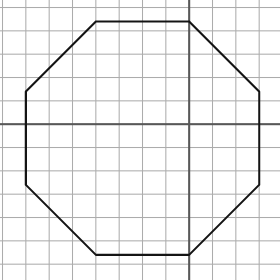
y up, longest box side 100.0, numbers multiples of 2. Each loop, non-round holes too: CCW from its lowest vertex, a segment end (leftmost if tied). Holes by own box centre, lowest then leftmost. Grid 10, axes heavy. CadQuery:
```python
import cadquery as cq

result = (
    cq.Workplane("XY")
    .moveTo(-40.0, -56.0)
    .lineTo(0.0, -56.0)
    .lineTo(30.0, -26.0)
    .lineTo(30.0, 14.0)
    .lineTo(0.0, 44.0)
    .lineTo(-40.0, 44.0)
    .lineTo(-70.0, 14.0)
    .lineTo(-70.0, -26.0)
    .close()
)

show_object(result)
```